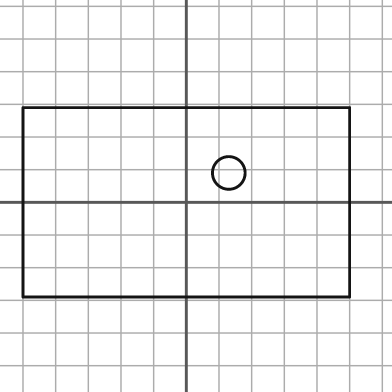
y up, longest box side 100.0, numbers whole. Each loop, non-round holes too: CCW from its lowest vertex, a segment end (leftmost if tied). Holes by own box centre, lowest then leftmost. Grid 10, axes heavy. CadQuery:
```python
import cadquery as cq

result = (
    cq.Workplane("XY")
    .moveTo(-50.0, -29.0)
    .lineTo(50.0, -29.0)
    .lineTo(50.0, 29.0)
    .lineTo(-50.0, 29.0)
    .close()
    .moveTo(13.0, 9.0)
    .circle(5.0)
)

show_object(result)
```